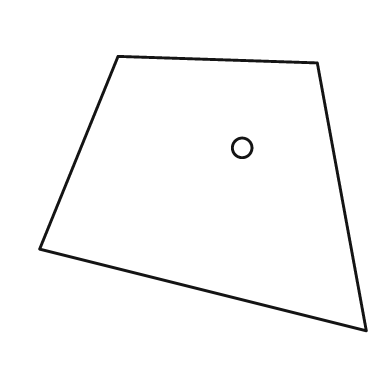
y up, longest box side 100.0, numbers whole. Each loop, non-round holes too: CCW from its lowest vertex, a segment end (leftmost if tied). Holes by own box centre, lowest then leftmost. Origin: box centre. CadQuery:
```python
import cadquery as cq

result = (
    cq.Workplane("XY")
    .moveTo(50.0, -42.0)
    .lineTo(35.0, 40.0)
    .lineTo(-26.0, 42.0)
    .lineTo(-50.0, -17.0)
    .close()
    .moveTo(12.0, 14.0)
    .circle(3.0)
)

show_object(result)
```